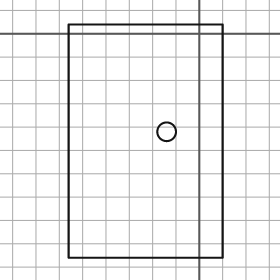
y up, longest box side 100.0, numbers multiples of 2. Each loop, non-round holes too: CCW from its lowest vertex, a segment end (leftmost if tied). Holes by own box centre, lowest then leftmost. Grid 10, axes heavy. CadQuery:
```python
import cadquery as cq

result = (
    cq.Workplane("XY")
    .moveTo(-56.0, -96.0)
    .lineTo(10.0, -96.0)
    .lineTo(10.0, 4.0)
    .lineTo(-56.0, 4.0)
    .close()
    .moveTo(-14.0, -42.0)
    .circle(4.0)
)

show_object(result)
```